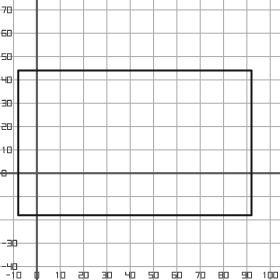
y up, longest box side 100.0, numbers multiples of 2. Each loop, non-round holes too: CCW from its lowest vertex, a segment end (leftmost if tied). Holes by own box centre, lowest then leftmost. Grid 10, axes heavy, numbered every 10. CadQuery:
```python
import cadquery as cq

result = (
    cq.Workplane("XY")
    .moveTo(-8.0, -18.0)
    .lineTo(92.0, -18.0)
    .lineTo(92.0, 44.0)
    .lineTo(-8.0, 44.0)
    .close()
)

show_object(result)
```